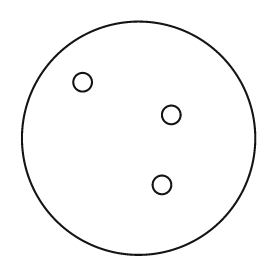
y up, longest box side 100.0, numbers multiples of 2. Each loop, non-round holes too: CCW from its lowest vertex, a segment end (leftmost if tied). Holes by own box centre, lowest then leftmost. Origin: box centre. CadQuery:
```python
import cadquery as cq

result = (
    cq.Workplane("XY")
    .moveTo(0.0, 0.0)
    .circle(50.0)
    .moveTo(10.0, -20.0)
    .circle(4.0)
    .moveTo(14.0, 10.0)
    .circle(4.0)
    .moveTo(-24.0, 24.0)
    .circle(4.0)
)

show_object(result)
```